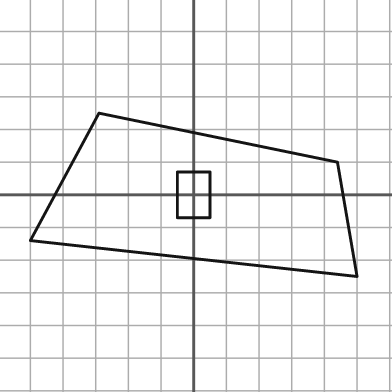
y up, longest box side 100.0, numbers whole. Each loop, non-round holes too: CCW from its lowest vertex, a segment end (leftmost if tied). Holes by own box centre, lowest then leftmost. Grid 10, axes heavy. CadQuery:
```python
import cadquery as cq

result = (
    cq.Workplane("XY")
    .moveTo(50.0, -25.0)
    .lineTo(44.0, 10.0)
    .lineTo(-29.0, 25.0)
    .lineTo(-50.0, -14.0)
    .close()
    .moveTo(-5.0, -7.0)
    .lineTo(5.0, -7.0)
    .lineTo(5.0, 7.0)
    .lineTo(-5.0, 7.0)
    .close()
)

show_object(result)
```